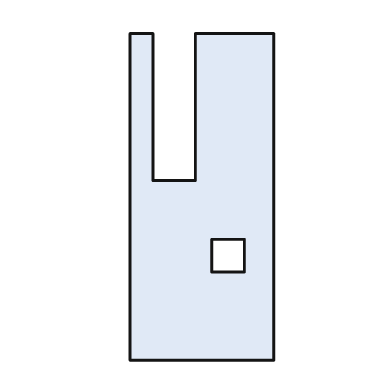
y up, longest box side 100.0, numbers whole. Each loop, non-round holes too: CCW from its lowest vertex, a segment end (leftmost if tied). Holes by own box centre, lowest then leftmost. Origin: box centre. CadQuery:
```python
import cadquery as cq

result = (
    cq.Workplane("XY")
    .moveTo(-22.0, -50.0)
    .lineTo(22.0, -50.0)
    .lineTo(22.0, 50.0)
    .lineTo(-2.0, 50.0)
    .lineTo(-2.0, 5.0)
    .lineTo(-15.0, 5.0)
    .lineTo(-15.0, 50.0)
    .lineTo(-22.0, 50.0)
    .close()
    .moveTo(3.0, -23.0)
    .lineTo(13.0, -23.0)
    .lineTo(13.0, -13.0)
    .lineTo(3.0, -13.0)
    .close()
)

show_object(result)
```